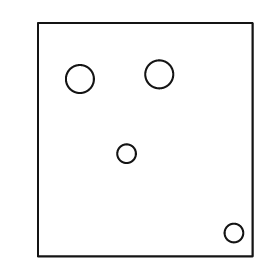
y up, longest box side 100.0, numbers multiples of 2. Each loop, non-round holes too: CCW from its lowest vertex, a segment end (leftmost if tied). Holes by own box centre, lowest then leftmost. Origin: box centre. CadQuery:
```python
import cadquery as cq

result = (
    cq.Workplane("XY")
    .moveTo(-46.0, -50.0)
    .lineTo(46.0, -50.0)
    .lineTo(46.0, 50.0)
    .lineTo(-46.0, 50.0)
    .close()
    .moveTo(38.0, -40.0)
    .circle(4.0)
    .moveTo(-8.0, -6.0)
    .circle(4.0)
    .moveTo(-28.0, 26.0)
    .circle(6.0)
    .moveTo(6.0, 28.0)
    .circle(6.0)
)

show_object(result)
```